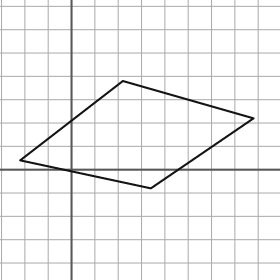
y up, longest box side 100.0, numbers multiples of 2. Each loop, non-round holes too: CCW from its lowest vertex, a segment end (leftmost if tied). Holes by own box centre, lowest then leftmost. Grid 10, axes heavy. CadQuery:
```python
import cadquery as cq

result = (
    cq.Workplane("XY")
    .moveTo(34.0, -8.0)
    .lineTo(78.0, 22.0)
    .lineTo(22.0, 38.0)
    .lineTo(-22.0, 4.0)
    .close()
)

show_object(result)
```